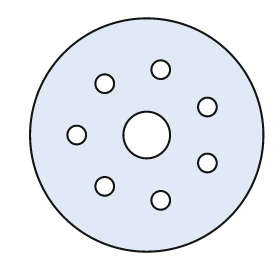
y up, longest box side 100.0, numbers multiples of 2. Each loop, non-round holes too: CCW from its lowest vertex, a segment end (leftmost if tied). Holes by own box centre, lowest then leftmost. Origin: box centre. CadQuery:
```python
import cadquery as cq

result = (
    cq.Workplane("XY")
    .moveTo(0.0, 0.0)
    .circle(50.0)
    .moveTo(6.0, -28.0)
    .circle(4.0)
    .moveTo(-18.0, -22.0)
    .circle(4.0)
    .moveTo(26.0, -12.0)
    .circle(4.0)
    .moveTo(-30.0, 0.0)
    .circle(4.0)
    .moveTo(0.0, 0.0)
    .circle(10.0)
    .moveTo(26.0, 12.0)
    .circle(4.0)
    .moveTo(-18.0, 22.0)
    .circle(4.0)
    .moveTo(6.0, 28.0)
    .circle(4.0)
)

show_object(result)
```